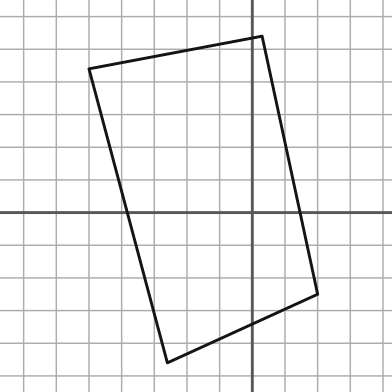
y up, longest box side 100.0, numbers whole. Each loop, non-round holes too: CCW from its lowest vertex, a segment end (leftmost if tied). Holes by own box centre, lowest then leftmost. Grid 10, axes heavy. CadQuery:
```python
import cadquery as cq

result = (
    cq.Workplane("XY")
    .moveTo(-26.0, -46.0)
    .lineTo(20.0, -25.0)
    .lineTo(3.0, 54.0)
    .lineTo(-50.0, 44.0)
    .close()
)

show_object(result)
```